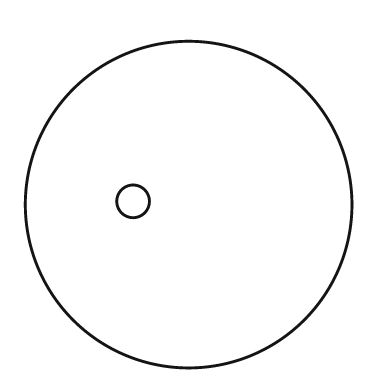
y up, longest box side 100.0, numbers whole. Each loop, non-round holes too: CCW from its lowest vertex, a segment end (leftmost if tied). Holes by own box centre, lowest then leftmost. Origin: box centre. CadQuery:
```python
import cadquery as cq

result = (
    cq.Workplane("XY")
    .moveTo(0.0, 0.0)
    .circle(50.0)
    .moveTo(-17.0, 1.0)
    .circle(5.0)
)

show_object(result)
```